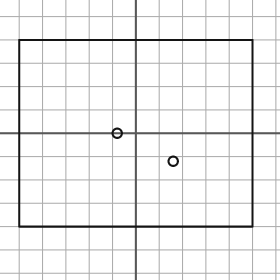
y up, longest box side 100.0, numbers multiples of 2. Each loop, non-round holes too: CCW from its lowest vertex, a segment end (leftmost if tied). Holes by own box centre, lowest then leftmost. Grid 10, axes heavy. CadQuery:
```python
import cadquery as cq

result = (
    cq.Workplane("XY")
    .moveTo(-50.0, -40.0)
    .lineTo(50.0, -40.0)
    .lineTo(50.0, 40.0)
    .lineTo(-50.0, 40.0)
    .close()
    .moveTo(16.0, -12.0)
    .circle(2.0)
    .moveTo(-8.0, 0.0)
    .circle(2.0)
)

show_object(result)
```